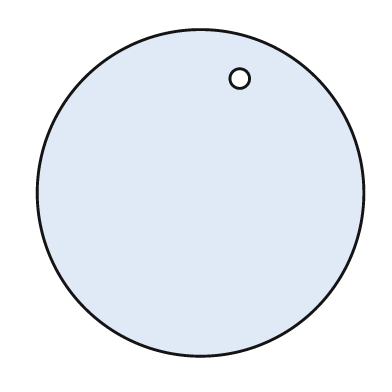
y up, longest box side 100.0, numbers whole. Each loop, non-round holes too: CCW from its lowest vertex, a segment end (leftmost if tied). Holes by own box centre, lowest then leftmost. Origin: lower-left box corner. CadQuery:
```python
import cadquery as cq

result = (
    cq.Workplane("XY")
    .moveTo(50.0, 50.0)
    .circle(50.0)
    .moveTo(62.0, 85.0)
    .circle(3.0)
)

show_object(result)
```